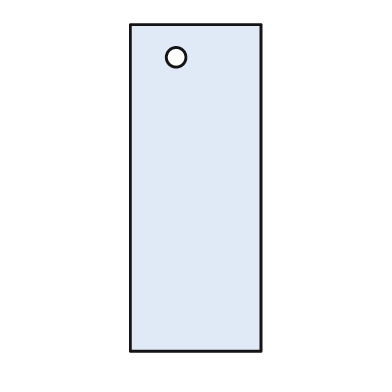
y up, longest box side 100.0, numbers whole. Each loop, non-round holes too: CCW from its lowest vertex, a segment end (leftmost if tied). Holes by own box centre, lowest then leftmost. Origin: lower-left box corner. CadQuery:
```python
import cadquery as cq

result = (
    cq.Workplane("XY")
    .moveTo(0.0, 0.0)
    .lineTo(40.0, 0.0)
    .lineTo(40.0, 100.0)
    .lineTo(0.0, 100.0)
    .close()
    .moveTo(14.0, 90.0)
    .circle(3.0)
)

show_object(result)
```